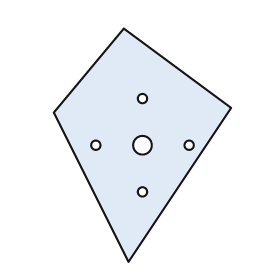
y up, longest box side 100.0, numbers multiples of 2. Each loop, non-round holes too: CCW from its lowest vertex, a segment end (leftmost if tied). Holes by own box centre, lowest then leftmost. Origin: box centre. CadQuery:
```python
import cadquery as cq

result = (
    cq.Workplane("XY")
    .moveTo(-6.0, -50.0)
    .lineTo(38.0, 16.0)
    .lineTo(-8.0, 50.0)
    .lineTo(-38.0, 14.0)
    .close()
    .moveTo(0.0, -20.0)
    .circle(2.0)
    .moveTo(-20.0, 0.0)
    .circle(2.0)
    .moveTo(0.0, 0.0)
    .circle(4.0)
    .moveTo(20.0, 0.0)
    .circle(2.0)
    .moveTo(0.0, 20.0)
    .circle(2.0)
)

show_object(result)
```